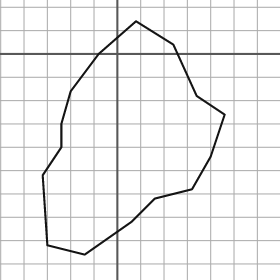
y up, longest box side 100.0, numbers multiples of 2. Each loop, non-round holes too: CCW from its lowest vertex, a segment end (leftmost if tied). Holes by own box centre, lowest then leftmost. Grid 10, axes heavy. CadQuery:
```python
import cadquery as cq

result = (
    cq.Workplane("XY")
    .moveTo(-14.0, -86.0)
    .lineTo(6.0, -72.0)
    .lineTo(16.0, -62.0)
    .lineTo(32.0, -58.0)
    .lineTo(40.0, -44.0)
    .lineTo(46.0, -26.0)
    .lineTo(34.0, -18.0)
    .lineTo(24.0, 4.0)
    .lineTo(8.0, 14.0)
    .lineTo(-8.0, 0.0)
    .lineTo(-20.0, -16.0)
    .lineTo(-24.0, -30.0)
    .lineTo(-24.0, -40.0)
    .lineTo(-32.0, -52.0)
    .lineTo(-30.0, -82.0)
    .close()
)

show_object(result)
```